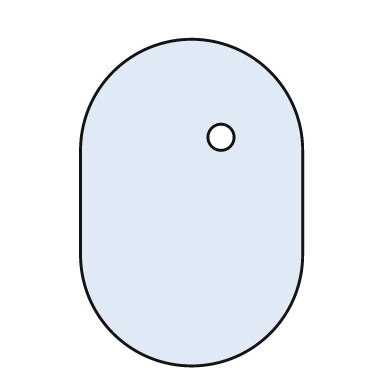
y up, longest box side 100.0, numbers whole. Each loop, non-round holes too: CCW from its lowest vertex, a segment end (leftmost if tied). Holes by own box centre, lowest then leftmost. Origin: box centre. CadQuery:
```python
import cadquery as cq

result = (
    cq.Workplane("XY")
    .moveTo(-34.0, -16.0)
    .threePointArc((0.0, -50.0), (34.0, -16.0))
    .lineTo(34.0, 16.0)
    .threePointArc((0.0, 50.0), (-34.0, 16.0))
    .close()
    .moveTo(9.0, 20.0)
    .circle(4.0)
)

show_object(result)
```